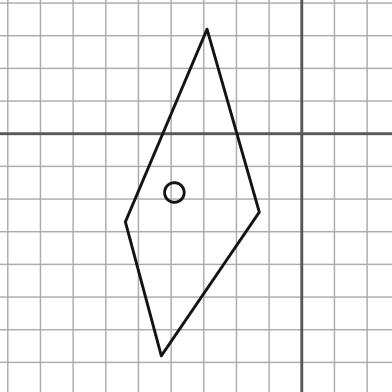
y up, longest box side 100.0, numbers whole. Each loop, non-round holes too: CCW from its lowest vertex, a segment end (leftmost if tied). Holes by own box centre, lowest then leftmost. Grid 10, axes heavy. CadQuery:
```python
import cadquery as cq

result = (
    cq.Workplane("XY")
    .moveTo(-43.0, -68.0)
    .lineTo(-13.0, -24.0)
    .lineTo(-29.0, 32.0)
    .lineTo(-54.0, -27.0)
    .close()
    .moveTo(-39.0, -18.0)
    .circle(3.0)
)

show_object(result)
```